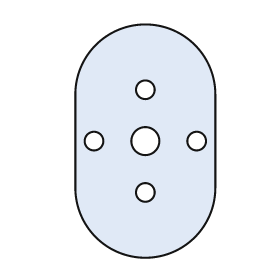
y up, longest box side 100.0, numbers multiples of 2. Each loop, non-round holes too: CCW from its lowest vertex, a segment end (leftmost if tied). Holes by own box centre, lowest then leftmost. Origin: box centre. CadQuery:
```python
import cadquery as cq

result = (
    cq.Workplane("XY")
    .moveTo(-30.0, -20.0)
    .threePointArc((0.0, -50.0), (30.0, -20.0))
    .lineTo(30.0, 20.0)
    .threePointArc((0.0, 50.0), (-30.0, 20.0))
    .close()
    .moveTo(0.0, -22.0)
    .circle(4.0)
    .moveTo(-22.0, 0.0)
    .circle(4.0)
    .moveTo(0.0, 0.0)
    .circle(6.0)
    .moveTo(22.0, 0.0)
    .circle(4.0)
    .moveTo(0.0, 22.0)
    .circle(4.0)
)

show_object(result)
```